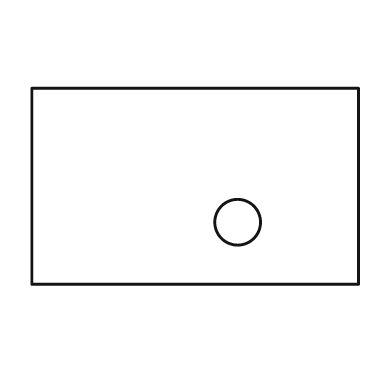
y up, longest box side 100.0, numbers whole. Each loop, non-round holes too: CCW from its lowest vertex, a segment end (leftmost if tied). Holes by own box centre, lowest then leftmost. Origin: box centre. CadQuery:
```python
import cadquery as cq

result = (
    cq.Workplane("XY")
    .moveTo(-50.0, -30.0)
    .lineTo(50.0, -30.0)
    .lineTo(50.0, 30.0)
    .lineTo(-50.0, 30.0)
    .close()
    .moveTo(13.0, -11.0)
    .circle(7.0)
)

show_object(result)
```